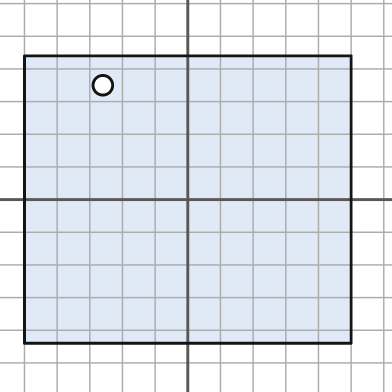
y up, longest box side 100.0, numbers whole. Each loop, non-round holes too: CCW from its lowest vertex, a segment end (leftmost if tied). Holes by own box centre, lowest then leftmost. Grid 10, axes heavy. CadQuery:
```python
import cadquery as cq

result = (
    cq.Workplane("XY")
    .moveTo(-50.0, -44.0)
    .lineTo(50.0, -44.0)
    .lineTo(50.0, 44.0)
    .lineTo(-50.0, 44.0)
    .close()
    .moveTo(-26.0, 35.0)
    .circle(3.0)
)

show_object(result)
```